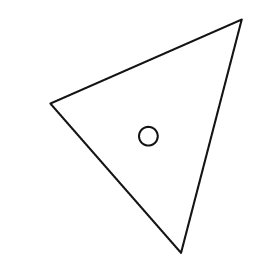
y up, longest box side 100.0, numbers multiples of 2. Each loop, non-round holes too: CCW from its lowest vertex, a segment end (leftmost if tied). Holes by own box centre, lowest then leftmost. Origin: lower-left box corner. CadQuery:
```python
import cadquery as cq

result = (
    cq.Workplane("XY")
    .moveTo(56.0, 0.0)
    .lineTo(82.0, 100.0)
    .lineTo(0.0, 64.0)
    .close()
    .moveTo(42.0, 50.0)
    .circle(4.0)
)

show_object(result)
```